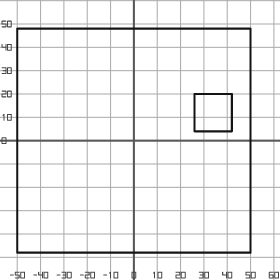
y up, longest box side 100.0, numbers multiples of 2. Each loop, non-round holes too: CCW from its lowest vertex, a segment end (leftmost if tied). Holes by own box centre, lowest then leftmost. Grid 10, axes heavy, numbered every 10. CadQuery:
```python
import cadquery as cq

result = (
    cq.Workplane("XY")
    .moveTo(-50.0, -48.0)
    .lineTo(50.0, -48.0)
    .lineTo(50.0, 48.0)
    .lineTo(-50.0, 48.0)
    .close()
    .moveTo(26.0, 4.0)
    .lineTo(42.0, 4.0)
    .lineTo(42.0, 20.0)
    .lineTo(26.0, 20.0)
    .close()
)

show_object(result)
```